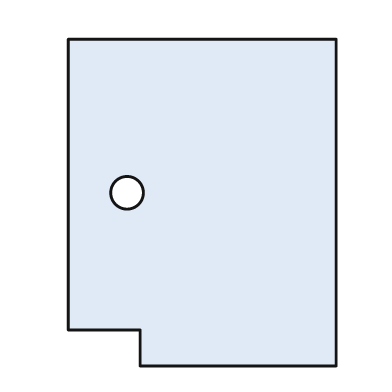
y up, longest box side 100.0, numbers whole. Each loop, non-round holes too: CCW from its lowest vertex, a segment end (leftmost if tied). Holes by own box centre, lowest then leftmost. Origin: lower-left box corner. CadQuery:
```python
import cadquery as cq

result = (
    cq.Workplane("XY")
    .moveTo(22.0, 0.0)
    .lineTo(82.0, 0.0)
    .lineTo(82.0, 100.0)
    .lineTo(0.0, 100.0)
    .lineTo(0.0, 11.0)
    .lineTo(22.0, 11.0)
    .close()
    .moveTo(18.0, 53.0)
    .circle(5.0)
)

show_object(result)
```